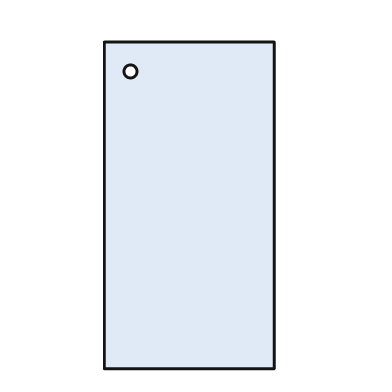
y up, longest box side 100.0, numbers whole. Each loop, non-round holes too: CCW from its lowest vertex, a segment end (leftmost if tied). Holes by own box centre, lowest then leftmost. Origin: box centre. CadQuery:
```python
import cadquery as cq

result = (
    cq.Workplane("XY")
    .moveTo(-26.0, -50.0)
    .lineTo(26.0, -50.0)
    .lineTo(26.0, 50.0)
    .lineTo(-26.0, 50.0)
    .close()
    .moveTo(-18.0, 41.0)
    .circle(2.0)
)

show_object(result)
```